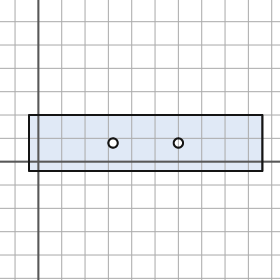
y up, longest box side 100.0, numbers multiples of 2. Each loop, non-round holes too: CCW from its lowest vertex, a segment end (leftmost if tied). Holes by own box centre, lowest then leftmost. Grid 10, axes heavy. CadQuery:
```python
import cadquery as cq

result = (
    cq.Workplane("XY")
    .moveTo(-4.0, -4.0)
    .lineTo(96.0, -4.0)
    .lineTo(96.0, 20.0)
    .lineTo(-4.0, 20.0)
    .close()
    .moveTo(32.0, 8.0)
    .circle(2.0)
    .moveTo(60.0, 8.0)
    .circle(2.0)
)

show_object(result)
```